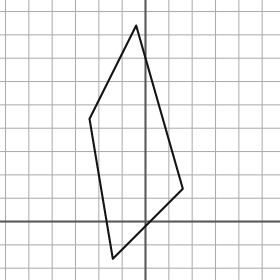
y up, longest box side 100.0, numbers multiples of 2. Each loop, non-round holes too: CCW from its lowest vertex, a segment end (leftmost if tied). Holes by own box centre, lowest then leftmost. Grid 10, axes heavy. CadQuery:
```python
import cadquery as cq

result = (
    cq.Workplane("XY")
    .moveTo(-14.0, -16.0)
    .lineTo(16.0, 14.0)
    .lineTo(-4.0, 84.0)
    .lineTo(-24.0, 44.0)
    .close()
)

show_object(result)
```